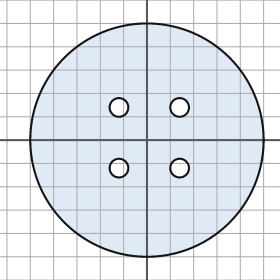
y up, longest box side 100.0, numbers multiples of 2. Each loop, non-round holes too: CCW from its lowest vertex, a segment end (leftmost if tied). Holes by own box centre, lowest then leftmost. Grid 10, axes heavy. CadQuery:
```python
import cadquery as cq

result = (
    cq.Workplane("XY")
    .moveTo(0.0, 0.0)
    .circle(50.0)
    .moveTo(-12.0, -12.0)
    .circle(4.0)
    .moveTo(14.0, -12.0)
    .circle(4.0)
    .moveTo(-12.0, 14.0)
    .circle(4.0)
    .moveTo(14.0, 14.0)
    .circle(4.0)
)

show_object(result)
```